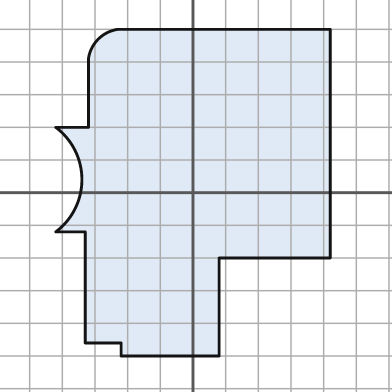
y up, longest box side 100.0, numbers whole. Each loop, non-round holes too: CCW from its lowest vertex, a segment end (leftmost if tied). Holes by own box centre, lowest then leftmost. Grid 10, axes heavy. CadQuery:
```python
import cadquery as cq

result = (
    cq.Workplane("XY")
    .moveTo(-22.0, -50.0)
    .lineTo(8.0, -50.0)
    .lineTo(8.0, -20.0)
    .lineTo(42.0, -20.0)
    .lineTo(42.0, 50.0)
    .lineTo(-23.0, 50.0)
    .threePointArc((-29.0, 47.0), (-32.0, 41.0))
    .lineTo(-32.0, 20.0)
    .lineTo(-42.0, 20.0)
    .threePointArc((-34.0, 4.0), (-42.0, -12.0))
    .lineTo(-33.0, -12.0)
    .lineTo(-33.0, -46.0)
    .lineTo(-22.0, -46.0)
    .close()
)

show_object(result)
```